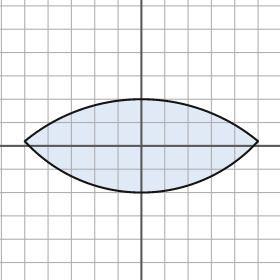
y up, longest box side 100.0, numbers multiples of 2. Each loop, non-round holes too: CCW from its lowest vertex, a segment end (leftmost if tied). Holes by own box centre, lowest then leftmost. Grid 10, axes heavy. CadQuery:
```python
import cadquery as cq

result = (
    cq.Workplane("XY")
    .moveTo(-50.0, 2.0)
    .threePointArc((0.0, -20.0), (50.0, 2.0))
    .threePointArc((0.0, 20.0), (-50.0, 2.0))
    .close()
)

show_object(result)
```